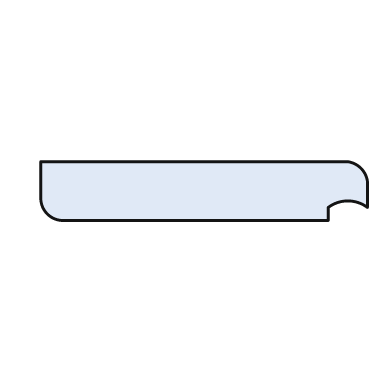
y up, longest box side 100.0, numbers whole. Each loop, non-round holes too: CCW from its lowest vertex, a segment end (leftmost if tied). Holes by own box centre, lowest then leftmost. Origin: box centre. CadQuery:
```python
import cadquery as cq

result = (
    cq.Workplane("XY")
    .moveTo(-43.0, -9.0)
    .lineTo(38.0, -9.0)
    .lineTo(38.0, -5.0)
    .threePointArc((44.0, -3.0), (50.0, -5.0))
    .lineTo(50.0, 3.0)
    .threePointArc((48.0, 7.0), (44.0, 9.0))
    .lineTo(-50.0, 9.0)
    .lineTo(-50.0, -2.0)
    .threePointArc((-48.0, -7.0), (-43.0, -9.0))
    .close()
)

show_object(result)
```